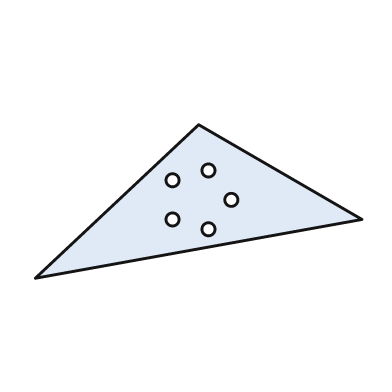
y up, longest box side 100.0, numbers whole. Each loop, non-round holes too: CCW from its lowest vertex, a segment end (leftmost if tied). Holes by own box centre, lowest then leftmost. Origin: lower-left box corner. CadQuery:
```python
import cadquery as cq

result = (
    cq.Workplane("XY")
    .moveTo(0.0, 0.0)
    .lineTo(100.0, 18.0)
    .lineTo(50.0, 47.0)
    .close()
    .moveTo(53.0, 15.0)
    .circle(2.0)
    .moveTo(42.0, 18.0)
    .circle(2.0)
    .moveTo(60.0, 24.0)
    .circle(2.0)
    .moveTo(42.0, 30.0)
    .circle(2.0)
    .moveTo(53.0, 33.0)
    .circle(2.0)
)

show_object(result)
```